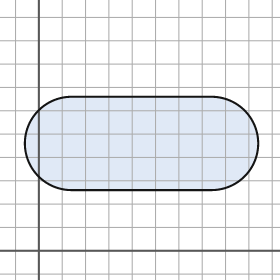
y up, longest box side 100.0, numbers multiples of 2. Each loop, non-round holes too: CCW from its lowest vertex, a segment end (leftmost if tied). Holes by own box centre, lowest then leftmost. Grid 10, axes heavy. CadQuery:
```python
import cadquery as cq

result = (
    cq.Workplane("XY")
    .moveTo(14.0, 26.0)
    .lineTo(74.0, 26.0)
    .threePointArc((94.0, 46.0), (74.0, 66.0))
    .lineTo(14.0, 66.0)
    .threePointArc((-6.0, 46.0), (14.0, 26.0))
    .close()
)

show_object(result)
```